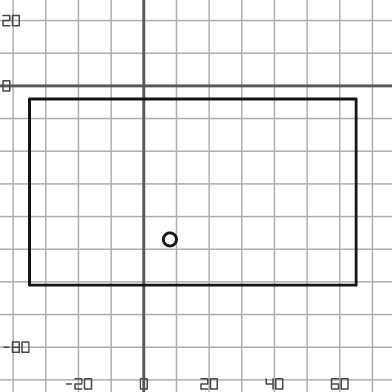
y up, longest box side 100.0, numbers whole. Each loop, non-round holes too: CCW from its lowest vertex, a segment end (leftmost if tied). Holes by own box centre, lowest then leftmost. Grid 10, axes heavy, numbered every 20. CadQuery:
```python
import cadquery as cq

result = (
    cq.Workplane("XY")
    .moveTo(-35.0, -61.0)
    .lineTo(65.0, -61.0)
    .lineTo(65.0, -4.0)
    .lineTo(-35.0, -4.0)
    .close()
    .moveTo(8.0, -47.0)
    .circle(2.0)
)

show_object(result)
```